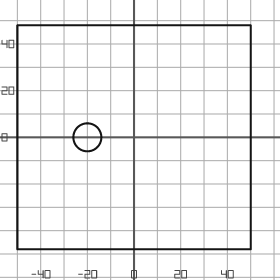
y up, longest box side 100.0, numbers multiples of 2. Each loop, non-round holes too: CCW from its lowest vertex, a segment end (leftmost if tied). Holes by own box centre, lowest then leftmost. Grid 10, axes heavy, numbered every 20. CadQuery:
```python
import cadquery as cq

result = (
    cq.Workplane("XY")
    .moveTo(-50.0, -48.0)
    .lineTo(50.0, -48.0)
    .lineTo(50.0, 48.0)
    .lineTo(-50.0, 48.0)
    .close()
    .moveTo(-20.0, 0.0)
    .circle(6.0)
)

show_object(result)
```